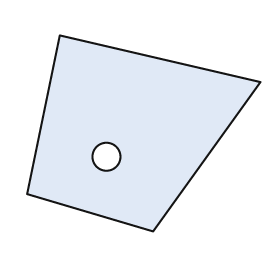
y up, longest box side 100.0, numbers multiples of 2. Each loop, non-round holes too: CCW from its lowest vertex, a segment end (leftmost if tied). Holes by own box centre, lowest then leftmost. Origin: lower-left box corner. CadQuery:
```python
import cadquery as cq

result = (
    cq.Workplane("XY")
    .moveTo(54.0, 0.0)
    .lineTo(100.0, 64.0)
    .lineTo(14.0, 84.0)
    .lineTo(0.0, 16.0)
    .close()
    .moveTo(34.0, 32.0)
    .circle(6.0)
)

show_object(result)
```